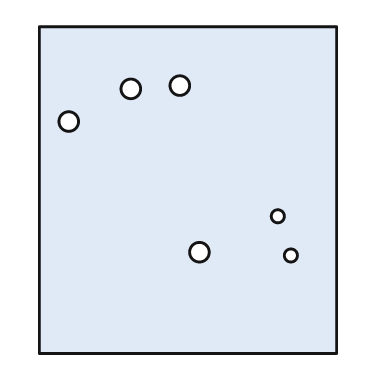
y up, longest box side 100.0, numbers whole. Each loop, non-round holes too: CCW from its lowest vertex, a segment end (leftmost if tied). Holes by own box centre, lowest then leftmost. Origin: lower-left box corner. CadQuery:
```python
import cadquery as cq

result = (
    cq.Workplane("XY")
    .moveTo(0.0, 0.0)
    .lineTo(91.0, 0.0)
    .lineTo(91.0, 100.0)
    .lineTo(0.0, 100.0)
    .close()
    .moveTo(77.0, 30.0)
    .circle(2.0)
    .moveTo(49.0, 31.0)
    .circle(3.0)
    .moveTo(73.0, 42.0)
    .circle(2.0)
    .moveTo(9.0, 71.0)
    .circle(3.0)
    .moveTo(28.0, 81.0)
    .circle(3.0)
    .moveTo(43.0, 82.0)
    .circle(3.0)
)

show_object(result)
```